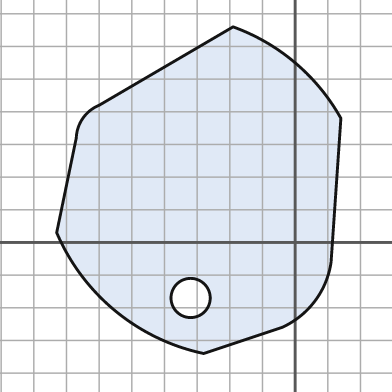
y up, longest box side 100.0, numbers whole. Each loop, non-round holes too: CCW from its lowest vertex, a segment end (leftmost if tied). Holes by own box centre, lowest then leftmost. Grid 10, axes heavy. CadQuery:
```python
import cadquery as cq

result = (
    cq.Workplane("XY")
    .moveTo(-28.0, -34.0)
    .lineTo(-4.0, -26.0)
    .threePointArc((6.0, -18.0), (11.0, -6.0))
    .lineTo(14.0, 38.0)
    .threePointArc((0.0, 55.0), (-19.0, 66.0))
    .lineTo(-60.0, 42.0)
    .threePointArc((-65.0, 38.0), (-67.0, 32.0))
    .lineTo(-73.0, 3.0)
    .threePointArc((-55.0, -21.0), (-28.0, -34.0))
    .close()
    .moveTo(-32.0, -17.0)
    .circle(6.0)
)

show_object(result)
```